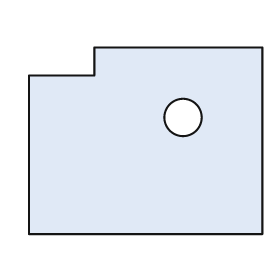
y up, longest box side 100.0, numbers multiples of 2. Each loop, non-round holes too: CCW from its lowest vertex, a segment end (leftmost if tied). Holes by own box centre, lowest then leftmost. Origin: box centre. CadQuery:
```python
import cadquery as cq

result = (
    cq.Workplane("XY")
    .moveTo(-50.0, -40.0)
    .lineTo(50.0, -40.0)
    .lineTo(50.0, 40.0)
    .lineTo(-22.0, 40.0)
    .lineTo(-22.0, 28.0)
    .lineTo(-50.0, 28.0)
    .close()
    .moveTo(16.0, 10.0)
    .circle(8.0)
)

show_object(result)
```